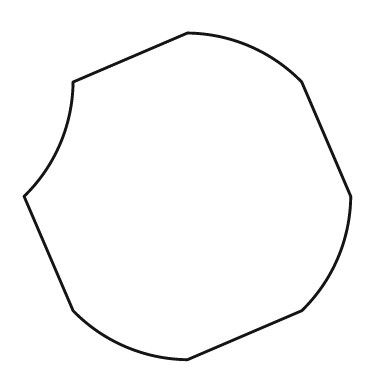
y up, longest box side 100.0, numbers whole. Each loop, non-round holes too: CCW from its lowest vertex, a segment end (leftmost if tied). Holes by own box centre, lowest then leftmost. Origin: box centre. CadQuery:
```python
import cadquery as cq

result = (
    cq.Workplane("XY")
    .moveTo(0.0, -50.0)
    .lineTo(35.0, -35.0)
    .threePointArc((46.0, -19.0), (50.0, 0.0))
    .lineTo(35.0, 35.0)
    .threePointArc((19.0, 46.0), (0.0, 50.0))
    .lineTo(-35.0, 35.0)
    .threePointArc((-39.0, 16.0), (-50.0, 0.0))
    .lineTo(-35.0, -35.0)
    .threePointArc((-19.0, -46.0), (0.0, -50.0))
    .close()
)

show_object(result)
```